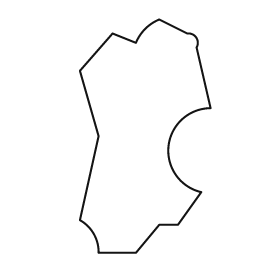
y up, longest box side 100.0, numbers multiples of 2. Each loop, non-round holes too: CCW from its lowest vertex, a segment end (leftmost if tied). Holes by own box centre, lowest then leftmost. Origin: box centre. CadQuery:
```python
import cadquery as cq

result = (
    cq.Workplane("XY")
    .moveTo(-20.0, -50.0)
    .lineTo(-4.0, -50.0)
    .lineTo(6.0, -38.0)
    .lineTo(14.0, -38.0)
    .lineTo(24.0, -24.0)
    .threePointArc((10.0, -4.0), (28.0, 12.0))
    .lineTo(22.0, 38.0)
    .threePointArc((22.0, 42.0), (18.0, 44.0))
    .lineTo(6.0, 50.0)
    .threePointArc((0.0, 46.0), (-4.0, 40.0))
    .lineTo(-14.0, 44.0)
    .lineTo(-28.0, 28.0)
    .lineTo(-20.0, 0.0)
    .lineTo(-28.0, -36.0)
    .threePointArc((-22.0, -42.0), (-20.0, -50.0))
    .close()
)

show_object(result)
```